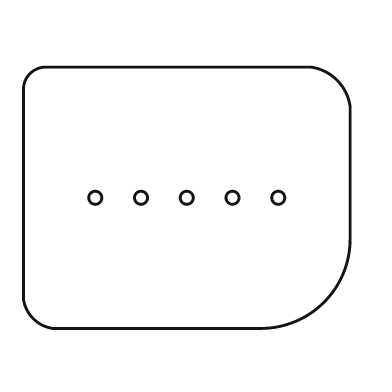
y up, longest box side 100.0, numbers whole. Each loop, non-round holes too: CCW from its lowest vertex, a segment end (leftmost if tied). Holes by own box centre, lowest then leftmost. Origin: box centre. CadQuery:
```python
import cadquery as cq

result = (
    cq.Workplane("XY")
    .moveTo(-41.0, -40.0)
    .lineTo(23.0, -40.0)
    .threePointArc((42.0, -32.0), (50.0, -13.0))
    .lineTo(50.0, 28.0)
    .threePointArc((46.0, 36.0), (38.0, 40.0))
    .lineTo(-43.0, 40.0)
    .threePointArc((-48.0, 38.0), (-50.0, 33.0))
    .lineTo(-50.0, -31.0)
    .threePointArc((-47.0, -37.0), (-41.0, -40.0))
    .close()
    .moveTo(-28.0, 0.0)
    .circle(2.0)
    .moveTo(-14.0, 0.0)
    .circle(2.0)
    .moveTo(0.0, 0.0)
    .circle(2.0)
    .moveTo(14.0, 0.0)
    .circle(2.0)
    .moveTo(28.0, 0.0)
    .circle(2.0)
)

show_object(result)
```